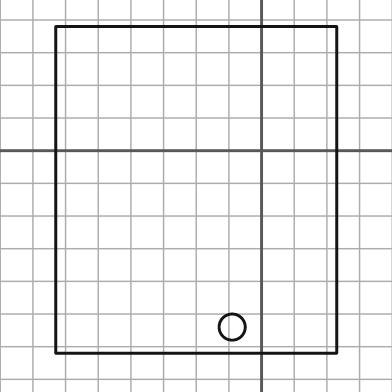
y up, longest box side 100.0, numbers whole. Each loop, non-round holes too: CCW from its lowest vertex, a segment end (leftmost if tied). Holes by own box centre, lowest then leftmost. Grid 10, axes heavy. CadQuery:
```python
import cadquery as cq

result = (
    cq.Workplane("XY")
    .moveTo(-63.0, -62.0)
    .lineTo(23.0, -62.0)
    .lineTo(23.0, 38.0)
    .lineTo(-63.0, 38.0)
    .close()
    .moveTo(-9.0, -54.0)
    .circle(4.0)
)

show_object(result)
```